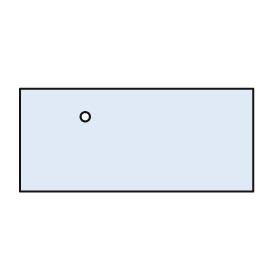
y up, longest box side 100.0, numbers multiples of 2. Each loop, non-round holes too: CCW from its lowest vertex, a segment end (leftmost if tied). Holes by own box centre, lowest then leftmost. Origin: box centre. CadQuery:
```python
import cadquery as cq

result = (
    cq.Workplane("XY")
    .moveTo(-50.0, -22.0)
    .lineTo(50.0, -22.0)
    .lineTo(50.0, 22.0)
    .lineTo(-50.0, 22.0)
    .close()
    .moveTo(-22.0, 10.0)
    .circle(2.0)
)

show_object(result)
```